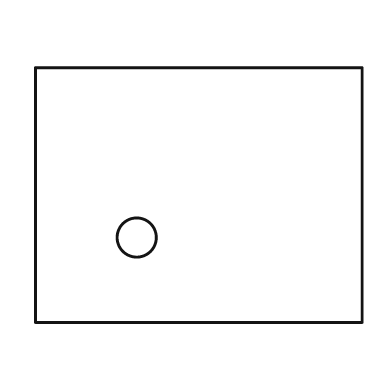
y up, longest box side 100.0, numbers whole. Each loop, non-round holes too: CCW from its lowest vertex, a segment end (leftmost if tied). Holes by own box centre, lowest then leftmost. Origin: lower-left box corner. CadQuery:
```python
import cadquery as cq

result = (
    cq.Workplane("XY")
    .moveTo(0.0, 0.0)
    .lineTo(100.0, 0.0)
    .lineTo(100.0, 78.0)
    .lineTo(0.0, 78.0)
    .close()
    .moveTo(31.0, 26.0)
    .circle(6.0)
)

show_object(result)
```